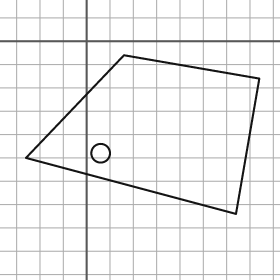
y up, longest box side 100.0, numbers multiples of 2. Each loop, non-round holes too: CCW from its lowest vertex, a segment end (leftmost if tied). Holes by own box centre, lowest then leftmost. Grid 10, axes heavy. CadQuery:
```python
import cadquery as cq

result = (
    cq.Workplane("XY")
    .moveTo(64.0, -74.0)
    .lineTo(74.0, -16.0)
    .lineTo(16.0, -6.0)
    .lineTo(-26.0, -50.0)
    .close()
    .moveTo(6.0, -48.0)
    .circle(4.0)
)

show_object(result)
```